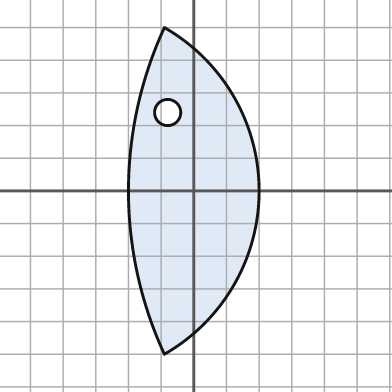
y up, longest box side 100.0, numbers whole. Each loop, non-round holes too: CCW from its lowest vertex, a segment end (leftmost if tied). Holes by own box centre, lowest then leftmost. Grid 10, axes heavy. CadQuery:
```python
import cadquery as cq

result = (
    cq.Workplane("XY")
    .moveTo(-9.0, -50.0)
    .threePointArc((20.0, 0.0), (-9.0, 50.0))
    .threePointArc((-20.0, 0.0), (-9.0, -50.0))
    .close()
    .moveTo(-8.0, 24.0)
    .circle(4.0)
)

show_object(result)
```